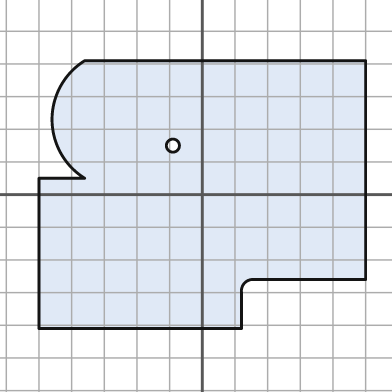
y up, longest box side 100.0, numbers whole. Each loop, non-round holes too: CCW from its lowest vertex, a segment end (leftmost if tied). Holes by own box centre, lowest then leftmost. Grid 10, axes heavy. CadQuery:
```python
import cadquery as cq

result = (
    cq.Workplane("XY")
    .moveTo(-50.0, -41.0)
    .lineTo(12.0, -41.0)
    .lineTo(12.0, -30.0)
    .threePointArc((13.0, -27.0), (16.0, -26.0))
    .lineTo(50.0, -26.0)
    .lineTo(50.0, 41.0)
    .lineTo(-36.0, 41.0)
    .threePointArc((-46.0, 23.0), (-36.0, 5.0))
    .lineTo(-50.0, 5.0)
    .close()
    .moveTo(-9.0, 15.0)
    .circle(2.0)
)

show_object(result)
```